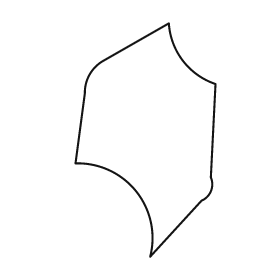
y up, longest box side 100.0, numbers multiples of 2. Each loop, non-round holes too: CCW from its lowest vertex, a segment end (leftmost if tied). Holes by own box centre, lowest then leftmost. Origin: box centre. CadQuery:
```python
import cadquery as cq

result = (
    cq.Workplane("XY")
    .moveTo(2.0, -50.0)
    .lineTo(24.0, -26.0)
    .threePointArc((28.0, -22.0), (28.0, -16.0))
    .lineTo(30.0, 24.0)
    .threePointArc((16.0, 34.0), (10.0, 50.0))
    .lineTo(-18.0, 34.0)
    .threePointArc((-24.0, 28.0), (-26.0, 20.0))
    .lineTo(-30.0, -10.0)
    .threePointArc((-4.0, -22.0), (2.0, -50.0))
    .close()
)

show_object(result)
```